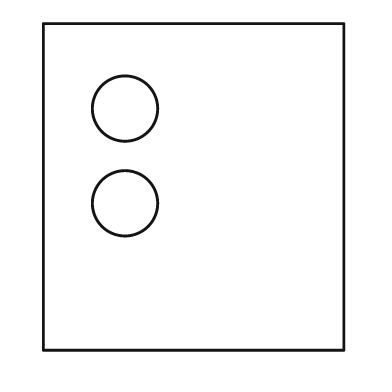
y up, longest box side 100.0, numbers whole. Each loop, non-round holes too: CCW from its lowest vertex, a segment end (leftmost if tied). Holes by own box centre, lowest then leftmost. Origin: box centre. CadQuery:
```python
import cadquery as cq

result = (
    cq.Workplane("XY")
    .moveTo(-46.0, -50.0)
    .lineTo(46.0, -50.0)
    .lineTo(46.0, 50.0)
    .lineTo(-46.0, 50.0)
    .close()
    .moveTo(-21.0, -5.0)
    .circle(10.0)
    .moveTo(-21.0, 24.0)
    .circle(10.0)
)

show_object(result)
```